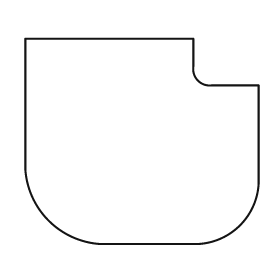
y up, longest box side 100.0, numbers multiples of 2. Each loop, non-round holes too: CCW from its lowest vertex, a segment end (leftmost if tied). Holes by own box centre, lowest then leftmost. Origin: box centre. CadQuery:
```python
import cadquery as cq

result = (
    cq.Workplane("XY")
    .moveTo(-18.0, -44.0)
    .lineTo(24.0, -44.0)
    .threePointArc((42.0, -36.0), (50.0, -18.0))
    .lineTo(50.0, 24.0)
    .lineTo(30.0, 24.0)
    .threePointArc((24.0, 26.0), (22.0, 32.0))
    .lineTo(22.0, 44.0)
    .lineTo(-50.0, 44.0)
    .lineTo(-50.0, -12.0)
    .threePointArc((-40.0, -34.0), (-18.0, -44.0))
    .close()
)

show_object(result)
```